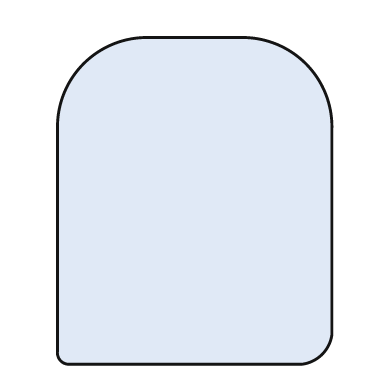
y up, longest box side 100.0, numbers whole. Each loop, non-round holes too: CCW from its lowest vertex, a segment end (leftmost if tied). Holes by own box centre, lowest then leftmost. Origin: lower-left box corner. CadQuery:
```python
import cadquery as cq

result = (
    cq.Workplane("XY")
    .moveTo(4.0, 0.0)
    .lineTo(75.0, 0.0)
    .threePointArc((81.0, 3.0), (84.0, 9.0))
    .lineTo(84.0, 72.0)
    .threePointArc((76.0, 92.0), (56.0, 100.0))
    .lineTo(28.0, 100.0)
    .threePointArc((8.0, 92.0), (0.0, 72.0))
    .lineTo(0.0, 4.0)
    .threePointArc((1.0, 1.0), (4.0, 0.0))
    .close()
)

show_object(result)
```